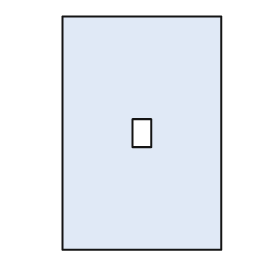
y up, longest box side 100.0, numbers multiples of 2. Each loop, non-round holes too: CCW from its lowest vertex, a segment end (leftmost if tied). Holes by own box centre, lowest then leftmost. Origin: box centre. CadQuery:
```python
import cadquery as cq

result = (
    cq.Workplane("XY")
    .moveTo(-34.0, -50.0)
    .lineTo(34.0, -50.0)
    .lineTo(34.0, 50.0)
    .lineTo(-34.0, 50.0)
    .close()
    .moveTo(-4.0, -6.0)
    .lineTo(4.0, -6.0)
    .lineTo(4.0, 6.0)
    .lineTo(-4.0, 6.0)
    .close()
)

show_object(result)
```